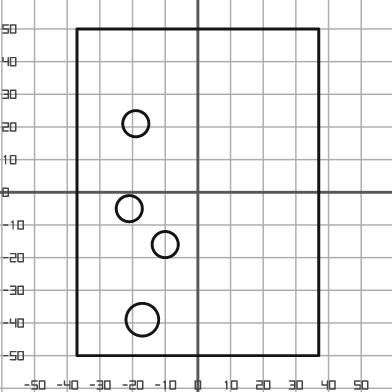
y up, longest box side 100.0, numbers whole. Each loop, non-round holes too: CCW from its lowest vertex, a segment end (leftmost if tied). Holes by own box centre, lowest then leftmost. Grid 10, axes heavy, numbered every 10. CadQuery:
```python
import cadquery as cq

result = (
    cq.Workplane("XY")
    .moveTo(-37.0, -50.0)
    .lineTo(37.0, -50.0)
    .lineTo(37.0, 50.0)
    .lineTo(-37.0, 50.0)
    .close()
    .moveTo(-17.0, -39.0)
    .circle(5.0)
    .moveTo(-10.0, -16.0)
    .circle(4.0)
    .moveTo(-21.0, -5.0)
    .circle(4.0)
    .moveTo(-19.0, 21.0)
    .circle(4.0)
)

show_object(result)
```